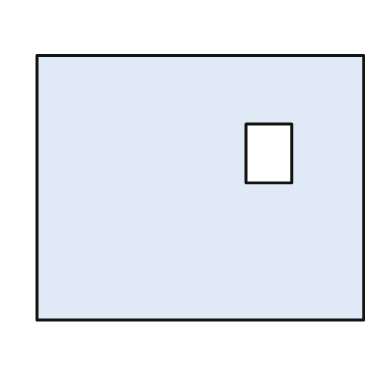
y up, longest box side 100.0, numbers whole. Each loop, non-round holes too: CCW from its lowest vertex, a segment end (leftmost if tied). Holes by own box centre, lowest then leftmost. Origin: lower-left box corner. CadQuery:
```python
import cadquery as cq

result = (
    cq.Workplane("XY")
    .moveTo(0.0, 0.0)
    .lineTo(100.0, 0.0)
    .lineTo(100.0, 81.0)
    .lineTo(0.0, 81.0)
    .close()
    .moveTo(64.0, 42.0)
    .lineTo(78.0, 42.0)
    .lineTo(78.0, 60.0)
    .lineTo(64.0, 60.0)
    .close()
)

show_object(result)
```